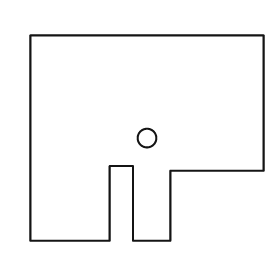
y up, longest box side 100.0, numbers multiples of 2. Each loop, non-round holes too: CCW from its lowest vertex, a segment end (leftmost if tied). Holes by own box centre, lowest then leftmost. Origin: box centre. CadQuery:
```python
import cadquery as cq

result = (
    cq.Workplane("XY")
    .moveTo(-50.0, -44.0)
    .lineTo(-16.0, -44.0)
    .lineTo(-16.0, -12.0)
    .lineTo(-6.0, -12.0)
    .lineTo(-6.0, -44.0)
    .lineTo(10.0, -44.0)
    .lineTo(10.0, -14.0)
    .lineTo(50.0, -14.0)
    .lineTo(50.0, 44.0)
    .lineTo(-50.0, 44.0)
    .close()
    .moveTo(0.0, 0.0)
    .circle(4.0)
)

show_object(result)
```